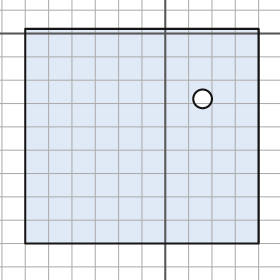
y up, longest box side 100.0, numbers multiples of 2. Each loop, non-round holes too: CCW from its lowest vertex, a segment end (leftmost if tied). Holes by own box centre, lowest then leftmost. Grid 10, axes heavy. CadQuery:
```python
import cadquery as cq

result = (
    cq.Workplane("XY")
    .moveTo(-60.0, -90.0)
    .lineTo(40.0, -90.0)
    .lineTo(40.0, 2.0)
    .lineTo(-60.0, 2.0)
    .close()
    .moveTo(16.0, -28.0)
    .circle(4.0)
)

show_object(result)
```